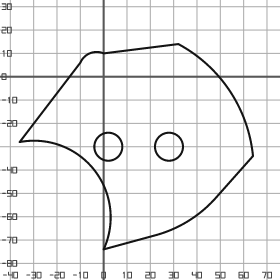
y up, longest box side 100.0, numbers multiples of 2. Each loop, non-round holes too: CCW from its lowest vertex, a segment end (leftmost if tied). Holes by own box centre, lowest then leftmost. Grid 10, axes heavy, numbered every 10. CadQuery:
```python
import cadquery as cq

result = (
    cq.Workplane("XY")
    .moveTo(0.0, -74.0)
    .lineTo(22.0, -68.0)
    .threePointArc((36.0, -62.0), (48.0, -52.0))
    .lineTo(64.0, -34.0)
    .threePointArc((54.0, -6.0), (32.0, 14.0))
    .lineTo(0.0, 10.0)
    .threePointArc((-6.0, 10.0), (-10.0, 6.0))
    .lineTo(-36.0, -28.0)
    .threePointArc((-4.0, -40.0), (0.0, -74.0))
    .close()
    .moveTo(2.0, -30.0)
    .circle(6.0)
    .moveTo(28.0, -30.0)
    .circle(6.0)
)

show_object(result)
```